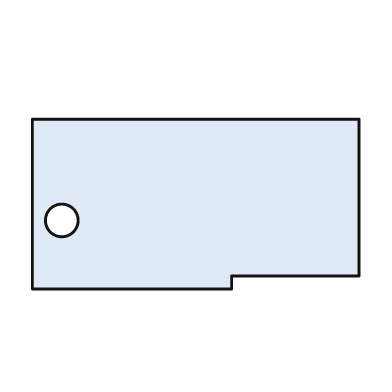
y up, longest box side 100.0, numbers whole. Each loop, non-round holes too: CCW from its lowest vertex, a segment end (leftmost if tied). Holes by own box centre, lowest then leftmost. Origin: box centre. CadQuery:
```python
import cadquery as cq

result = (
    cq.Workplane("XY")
    .moveTo(-50.0, -26.0)
    .lineTo(11.0, -26.0)
    .lineTo(11.0, -22.0)
    .lineTo(50.0, -22.0)
    .lineTo(50.0, 26.0)
    .lineTo(-50.0, 26.0)
    .close()
    .moveTo(-41.0, -5.0)
    .circle(5.0)
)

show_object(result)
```